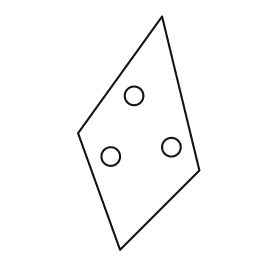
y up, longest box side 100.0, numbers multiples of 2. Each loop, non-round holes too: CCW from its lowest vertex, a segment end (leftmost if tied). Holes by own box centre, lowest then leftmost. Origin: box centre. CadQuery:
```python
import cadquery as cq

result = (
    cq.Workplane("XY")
    .moveTo(-8.0, -50.0)
    .lineTo(26.0, -16.0)
    .lineTo(10.0, 50.0)
    .lineTo(-26.0, 0.0)
    .close()
    .moveTo(-12.0, -10.0)
    .circle(4.0)
    .moveTo(14.0, -6.0)
    .circle(4.0)
    .moveTo(-2.0, 16.0)
    .circle(4.0)
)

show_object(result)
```